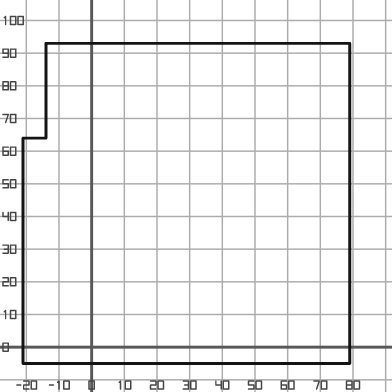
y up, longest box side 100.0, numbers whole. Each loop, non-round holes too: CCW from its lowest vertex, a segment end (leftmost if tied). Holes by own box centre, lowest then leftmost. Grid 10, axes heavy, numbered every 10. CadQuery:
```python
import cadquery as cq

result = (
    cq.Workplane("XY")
    .moveTo(-21.0, -5.0)
    .lineTo(79.0, -5.0)
    .lineTo(79.0, 93.0)
    .lineTo(-14.0, 93.0)
    .lineTo(-14.0, 64.0)
    .lineTo(-21.0, 64.0)
    .close()
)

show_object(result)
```